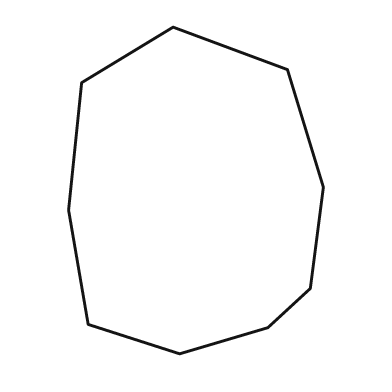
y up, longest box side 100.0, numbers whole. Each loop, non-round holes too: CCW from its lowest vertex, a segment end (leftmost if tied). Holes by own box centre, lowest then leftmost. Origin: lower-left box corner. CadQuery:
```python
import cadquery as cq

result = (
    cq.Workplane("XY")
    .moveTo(34.0, 0.0)
    .lineTo(61.0, 8.0)
    .lineTo(74.0, 20.0)
    .lineTo(78.0, 51.0)
    .lineTo(67.0, 87.0)
    .lineTo(32.0, 100.0)
    .lineTo(4.0, 83.0)
    .lineTo(0.0, 44.0)
    .lineTo(6.0, 9.0)
    .close()
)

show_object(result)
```